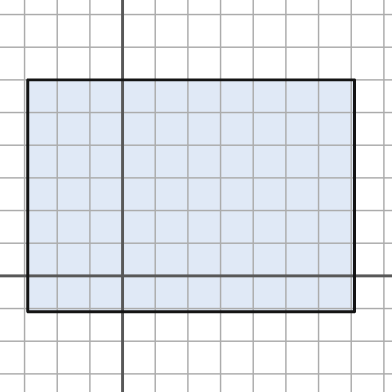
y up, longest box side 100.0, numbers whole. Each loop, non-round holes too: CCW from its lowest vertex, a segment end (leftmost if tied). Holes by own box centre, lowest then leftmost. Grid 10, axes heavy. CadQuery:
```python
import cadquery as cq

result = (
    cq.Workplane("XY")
    .moveTo(-29.0, -11.0)
    .lineTo(71.0, -11.0)
    .lineTo(71.0, 60.0)
    .lineTo(-29.0, 60.0)
    .close()
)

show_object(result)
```